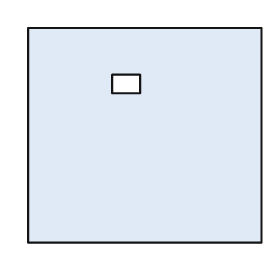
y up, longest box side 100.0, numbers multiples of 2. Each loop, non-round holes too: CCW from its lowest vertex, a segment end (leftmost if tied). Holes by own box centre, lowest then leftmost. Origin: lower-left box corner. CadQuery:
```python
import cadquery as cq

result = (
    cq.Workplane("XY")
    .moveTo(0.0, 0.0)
    .lineTo(100.0, 0.0)
    .lineTo(100.0, 92.0)
    .lineTo(0.0, 92.0)
    .close()
    .moveTo(36.0, 64.0)
    .lineTo(48.0, 64.0)
    .lineTo(48.0, 72.0)
    .lineTo(36.0, 72.0)
    .close()
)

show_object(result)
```